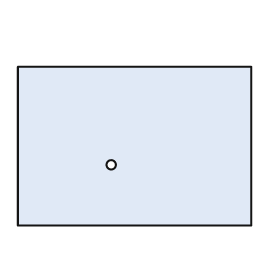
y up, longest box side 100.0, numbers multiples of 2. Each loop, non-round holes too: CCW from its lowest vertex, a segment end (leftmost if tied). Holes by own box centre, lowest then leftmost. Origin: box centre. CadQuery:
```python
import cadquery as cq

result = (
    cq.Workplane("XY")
    .moveTo(-50.0, -34.0)
    .lineTo(50.0, -34.0)
    .lineTo(50.0, 34.0)
    .lineTo(-50.0, 34.0)
    .close()
    .moveTo(-10.0, -8.0)
    .circle(2.0)
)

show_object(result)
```